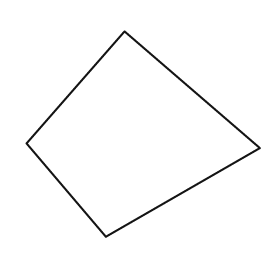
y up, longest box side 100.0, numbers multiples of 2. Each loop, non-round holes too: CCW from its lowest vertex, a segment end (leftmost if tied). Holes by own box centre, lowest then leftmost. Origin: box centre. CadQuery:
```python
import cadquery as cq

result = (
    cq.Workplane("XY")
    .moveTo(-16.0, -44.0)
    .lineTo(50.0, -6.0)
    .lineTo(-8.0, 44.0)
    .lineTo(-50.0, -4.0)
    .close()
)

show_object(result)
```